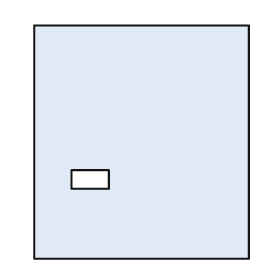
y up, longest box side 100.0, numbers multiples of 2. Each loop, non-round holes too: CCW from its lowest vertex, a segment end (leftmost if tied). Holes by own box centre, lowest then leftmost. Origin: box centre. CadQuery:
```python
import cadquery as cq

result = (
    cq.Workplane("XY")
    .moveTo(-46.0, -50.0)
    .lineTo(46.0, -50.0)
    .lineTo(46.0, 50.0)
    .lineTo(-46.0, 50.0)
    .close()
    .moveTo(-30.0, -20.0)
    .lineTo(-14.0, -20.0)
    .lineTo(-14.0, -12.0)
    .lineTo(-30.0, -12.0)
    .close()
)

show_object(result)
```